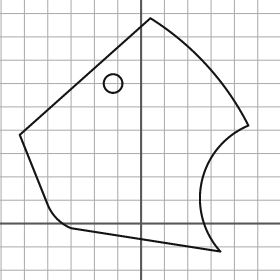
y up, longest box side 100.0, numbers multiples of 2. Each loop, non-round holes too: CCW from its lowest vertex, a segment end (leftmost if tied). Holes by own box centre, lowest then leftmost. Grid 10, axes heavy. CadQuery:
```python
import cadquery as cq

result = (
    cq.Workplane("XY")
    .moveTo(34.0, -12.0)
    .threePointArc((26.0, 18.0), (46.0, 42.0))
    .threePointArc((28.0, 68.0), (4.0, 88.0))
    .lineTo(-52.0, 38.0)
    .lineTo(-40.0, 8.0)
    .threePointArc((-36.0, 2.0), (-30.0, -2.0))
    .close()
    .moveTo(-12.0, 60.0)
    .circle(4.0)
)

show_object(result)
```